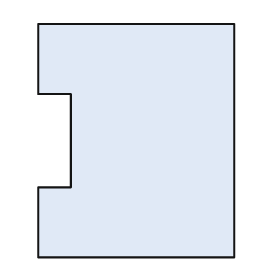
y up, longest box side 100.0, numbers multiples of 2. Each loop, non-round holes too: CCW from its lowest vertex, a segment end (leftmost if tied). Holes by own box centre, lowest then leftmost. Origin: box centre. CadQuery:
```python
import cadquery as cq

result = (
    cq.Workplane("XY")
    .moveTo(-42.0, -50.0)
    .lineTo(42.0, -50.0)
    .lineTo(42.0, 50.0)
    .lineTo(-42.0, 50.0)
    .lineTo(-42.0, 20.0)
    .lineTo(-28.0, 20.0)
    .lineTo(-28.0, -20.0)
    .lineTo(-42.0, -20.0)
    .close()
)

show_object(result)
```